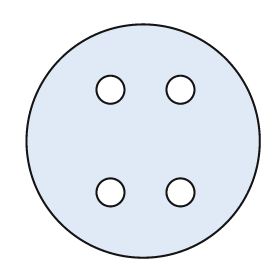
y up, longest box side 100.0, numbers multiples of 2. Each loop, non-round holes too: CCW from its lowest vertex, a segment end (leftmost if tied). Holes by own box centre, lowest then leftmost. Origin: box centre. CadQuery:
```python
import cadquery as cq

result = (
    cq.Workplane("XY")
    .moveTo(0.0, 0.0)
    .circle(50.0)
    .moveTo(-14.0, -22.0)
    .circle(6.0)
    .moveTo(16.0, -22.0)
    .circle(6.0)
    .moveTo(-14.0, 22.0)
    .circle(6.0)
    .moveTo(16.0, 22.0)
    .circle(6.0)
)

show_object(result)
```